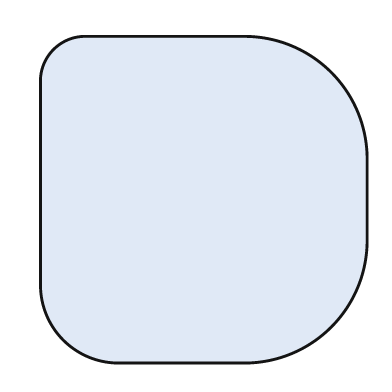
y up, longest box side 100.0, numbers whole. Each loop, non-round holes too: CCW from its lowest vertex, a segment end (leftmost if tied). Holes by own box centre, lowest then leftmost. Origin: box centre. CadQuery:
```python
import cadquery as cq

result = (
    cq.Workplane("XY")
    .moveTo(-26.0, -50.0)
    .lineTo(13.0, -50.0)
    .threePointArc((39.0, -39.0), (50.0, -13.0))
    .lineTo(50.0, 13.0)
    .threePointArc((39.0, 39.0), (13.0, 50.0))
    .lineTo(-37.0, 50.0)
    .threePointArc((-46.0, 46.0), (-50.0, 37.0))
    .lineTo(-50.0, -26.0)
    .threePointArc((-43.0, -43.0), (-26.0, -50.0))
    .close()
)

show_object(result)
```